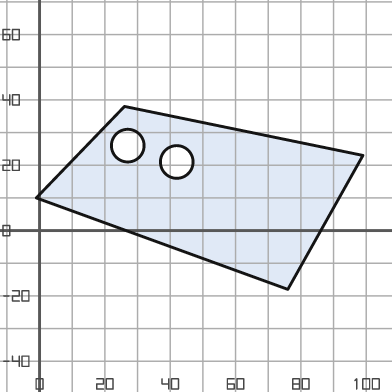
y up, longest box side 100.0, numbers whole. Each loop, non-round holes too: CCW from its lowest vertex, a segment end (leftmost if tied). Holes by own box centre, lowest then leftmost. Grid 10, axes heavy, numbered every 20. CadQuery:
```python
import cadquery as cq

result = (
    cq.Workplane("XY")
    .moveTo(76.0, -18.0)
    .lineTo(99.0, 23.0)
    .lineTo(26.0, 38.0)
    .lineTo(-1.0, 10.0)
    .close()
    .moveTo(42.0, 21.0)
    .circle(5.0)
    .moveTo(27.0, 26.0)
    .circle(5.0)
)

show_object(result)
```